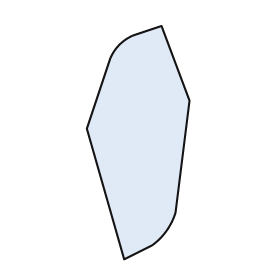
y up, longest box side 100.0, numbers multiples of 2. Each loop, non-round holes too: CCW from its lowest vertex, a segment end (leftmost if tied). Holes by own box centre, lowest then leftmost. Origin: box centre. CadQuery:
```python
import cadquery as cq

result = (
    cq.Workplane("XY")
    .moveTo(-6.0, -50.0)
    .lineTo(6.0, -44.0)
    .threePointArc((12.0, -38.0), (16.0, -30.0))
    .lineTo(22.0, 18.0)
    .lineTo(10.0, 50.0)
    .lineTo(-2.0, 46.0)
    .threePointArc((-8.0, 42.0), (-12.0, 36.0))
    .lineTo(-22.0, 6.0)
    .close()
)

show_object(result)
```